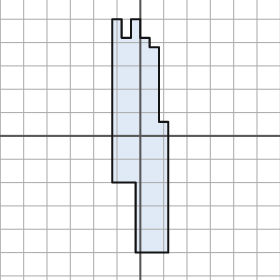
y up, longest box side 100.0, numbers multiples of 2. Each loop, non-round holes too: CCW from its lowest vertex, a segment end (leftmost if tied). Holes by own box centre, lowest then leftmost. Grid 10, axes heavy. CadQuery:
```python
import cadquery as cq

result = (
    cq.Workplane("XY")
    .moveTo(-2.0, -50.0)
    .lineTo(12.0, -50.0)
    .lineTo(12.0, 6.0)
    .lineTo(8.0, 6.0)
    .lineTo(8.0, 38.0)
    .lineTo(4.0, 38.0)
    .lineTo(4.0, 42.0)
    .lineTo(0.0, 42.0)
    .lineTo(0.0, 50.0)
    .lineTo(-4.0, 50.0)
    .lineTo(-4.0, 42.0)
    .lineTo(-8.0, 42.0)
    .lineTo(-8.0, 50.0)
    .lineTo(-12.0, 50.0)
    .lineTo(-12.0, -20.0)
    .lineTo(-2.0, -20.0)
    .close()
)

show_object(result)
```